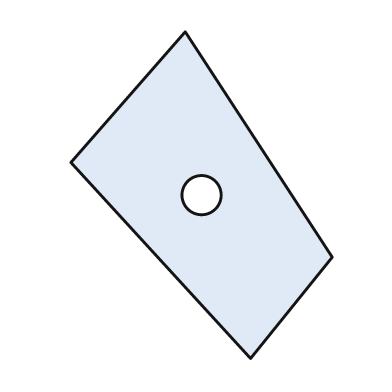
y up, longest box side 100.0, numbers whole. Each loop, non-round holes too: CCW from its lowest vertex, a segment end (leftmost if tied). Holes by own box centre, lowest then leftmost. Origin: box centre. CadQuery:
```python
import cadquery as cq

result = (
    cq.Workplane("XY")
    .moveTo(15.0, -50.0)
    .lineTo(40.0, -19.0)
    .lineTo(-5.0, 50.0)
    .lineTo(-40.0, 10.0)
    .close()
    .moveTo(0.0, 0.0)
    .circle(6.0)
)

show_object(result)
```